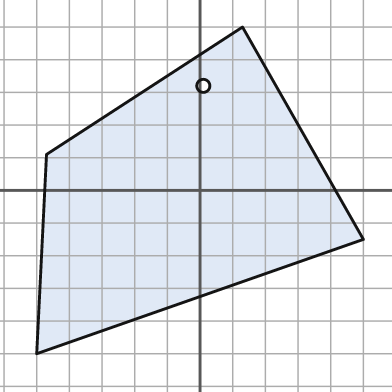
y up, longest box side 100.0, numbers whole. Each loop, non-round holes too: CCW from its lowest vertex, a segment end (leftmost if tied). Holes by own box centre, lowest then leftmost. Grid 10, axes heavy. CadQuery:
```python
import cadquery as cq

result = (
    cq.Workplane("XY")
    .moveTo(-50.0, -50.0)
    .lineTo(50.0, -15.0)
    .lineTo(13.0, 50.0)
    .lineTo(-47.0, 11.0)
    .close()
    .moveTo(1.0, 32.0)
    .circle(2.0)
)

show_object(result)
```